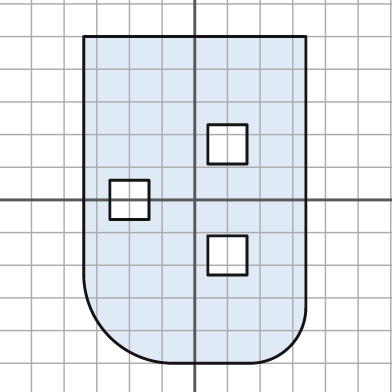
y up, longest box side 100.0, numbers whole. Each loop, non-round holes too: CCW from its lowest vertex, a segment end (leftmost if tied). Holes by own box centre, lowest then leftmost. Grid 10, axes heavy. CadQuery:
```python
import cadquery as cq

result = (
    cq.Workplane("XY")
    .moveTo(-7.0, -50.0)
    .lineTo(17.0, -50.0)
    .threePointArc((29.0, -45.0), (34.0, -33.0))
    .lineTo(34.0, 50.0)
    .lineTo(-34.0, 50.0)
    .lineTo(-34.0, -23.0)
    .threePointArc((-26.0, -42.0), (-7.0, -50.0))
    .close()
    .moveTo(4.0, -23.0)
    .lineTo(16.0, -23.0)
    .lineTo(16.0, -11.0)
    .lineTo(4.0, -11.0)
    .close()
    .moveTo(-26.0, -6.0)
    .lineTo(-14.0, -6.0)
    .lineTo(-14.0, 6.0)
    .lineTo(-26.0, 6.0)
    .close()
    .moveTo(4.0, 11.0)
    .lineTo(16.0, 11.0)
    .lineTo(16.0, 23.0)
    .lineTo(4.0, 23.0)
    .close()
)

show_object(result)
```